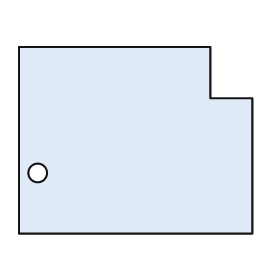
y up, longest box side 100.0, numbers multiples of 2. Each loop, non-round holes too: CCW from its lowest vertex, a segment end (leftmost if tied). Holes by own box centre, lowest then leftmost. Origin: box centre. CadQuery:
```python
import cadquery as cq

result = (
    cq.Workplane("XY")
    .moveTo(-50.0, -40.0)
    .lineTo(50.0, -40.0)
    .lineTo(50.0, 18.0)
    .lineTo(32.0, 18.0)
    .lineTo(32.0, 40.0)
    .lineTo(-50.0, 40.0)
    .close()
    .moveTo(-42.0, -14.0)
    .circle(4.0)
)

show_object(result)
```